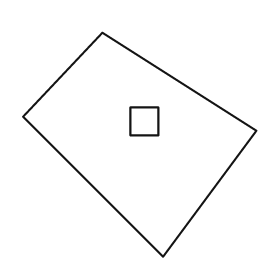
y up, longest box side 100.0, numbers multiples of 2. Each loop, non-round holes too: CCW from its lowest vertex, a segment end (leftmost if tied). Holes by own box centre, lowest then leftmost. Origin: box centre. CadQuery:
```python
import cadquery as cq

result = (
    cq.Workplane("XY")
    .moveTo(10.0, -48.0)
    .lineTo(50.0, 6.0)
    .lineTo(-16.0, 48.0)
    .lineTo(-50.0, 12.0)
    .close()
    .moveTo(-4.0, 4.0)
    .lineTo(8.0, 4.0)
    .lineTo(8.0, 16.0)
    .lineTo(-4.0, 16.0)
    .close()
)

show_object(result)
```